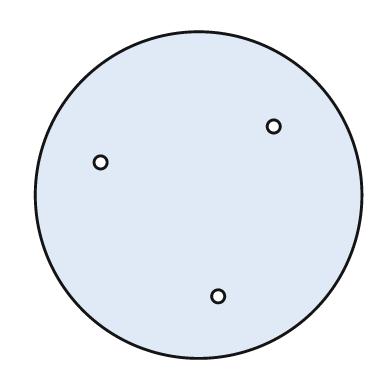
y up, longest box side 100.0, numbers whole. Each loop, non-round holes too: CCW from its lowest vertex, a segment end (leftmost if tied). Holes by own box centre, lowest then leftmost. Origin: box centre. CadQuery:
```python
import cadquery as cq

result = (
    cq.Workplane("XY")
    .moveTo(0.0, 0.0)
    .circle(50.0)
    .moveTo(6.0, -31.0)
    .circle(2.0)
    .moveTo(-30.0, 10.0)
    .circle(2.0)
    .moveTo(23.0, 21.0)
    .circle(2.0)
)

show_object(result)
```